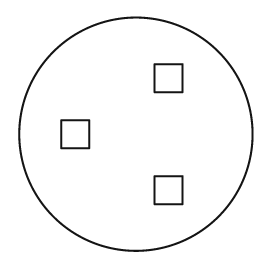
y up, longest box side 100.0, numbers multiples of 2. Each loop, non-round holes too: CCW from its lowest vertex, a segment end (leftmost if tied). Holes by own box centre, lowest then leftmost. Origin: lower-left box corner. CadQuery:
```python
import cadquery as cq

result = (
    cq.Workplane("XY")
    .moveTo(50.0, 50.0)
    .circle(50.0)
    .moveTo(58.0, 20.0)
    .lineTo(70.0, 20.0)
    .lineTo(70.0, 32.0)
    .lineTo(58.0, 32.0)
    .close()
    .moveTo(18.0, 44.0)
    .lineTo(30.0, 44.0)
    .lineTo(30.0, 56.0)
    .lineTo(18.0, 56.0)
    .close()
    .moveTo(58.0, 68.0)
    .lineTo(70.0, 68.0)
    .lineTo(70.0, 80.0)
    .lineTo(58.0, 80.0)
    .close()
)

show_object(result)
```